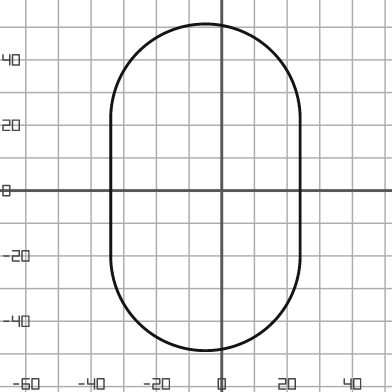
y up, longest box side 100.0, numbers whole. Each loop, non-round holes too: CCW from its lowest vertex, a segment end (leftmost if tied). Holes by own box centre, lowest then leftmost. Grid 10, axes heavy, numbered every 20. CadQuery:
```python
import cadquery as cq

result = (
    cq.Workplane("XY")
    .moveTo(-34.0, -20.0)
    .threePointArc((-5.0, -49.0), (24.0, -20.0))
    .lineTo(24.0, 22.0)
    .threePointArc((-5.0, 51.0), (-34.0, 22.0))
    .close()
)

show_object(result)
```